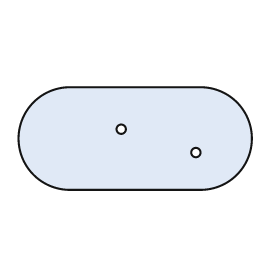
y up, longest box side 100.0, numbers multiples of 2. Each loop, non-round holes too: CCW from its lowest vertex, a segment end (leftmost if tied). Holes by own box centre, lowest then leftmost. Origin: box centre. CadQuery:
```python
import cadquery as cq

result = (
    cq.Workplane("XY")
    .moveTo(-28.0, -22.0)
    .lineTo(28.0, -22.0)
    .threePointArc((50.0, 0.0), (28.0, 22.0))
    .lineTo(-28.0, 22.0)
    .threePointArc((-50.0, 0.0), (-28.0, -22.0))
    .close()
    .moveTo(26.0, -6.0)
    .circle(2.0)
    .moveTo(-6.0, 4.0)
    .circle(2.0)
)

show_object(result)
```